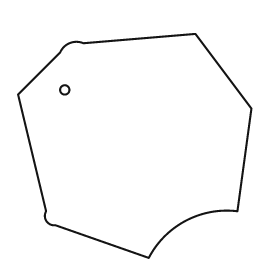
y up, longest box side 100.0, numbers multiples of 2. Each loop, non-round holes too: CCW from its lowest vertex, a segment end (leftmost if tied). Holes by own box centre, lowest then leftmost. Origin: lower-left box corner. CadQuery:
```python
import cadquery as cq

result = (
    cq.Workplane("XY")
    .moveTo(56.0, 0.0)
    .threePointArc((72.0, 16.0), (94.0, 20.0))
    .lineTo(100.0, 64.0)
    .lineTo(76.0, 96.0)
    .lineTo(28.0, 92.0)
    .threePointArc((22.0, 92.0), (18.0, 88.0))
    .lineTo(0.0, 70.0)
    .lineTo(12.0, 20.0)
    .threePointArc((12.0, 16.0), (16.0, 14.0))
    .close()
    .moveTo(20.0, 72.0)
    .circle(2.0)
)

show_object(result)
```